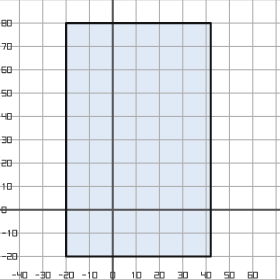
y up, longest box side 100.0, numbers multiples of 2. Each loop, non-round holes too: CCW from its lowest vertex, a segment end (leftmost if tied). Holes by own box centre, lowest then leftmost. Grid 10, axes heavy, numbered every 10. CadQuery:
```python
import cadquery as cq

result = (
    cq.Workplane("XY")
    .moveTo(-20.0, -20.0)
    .lineTo(42.0, -20.0)
    .lineTo(42.0, 80.0)
    .lineTo(-20.0, 80.0)
    .close()
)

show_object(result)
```